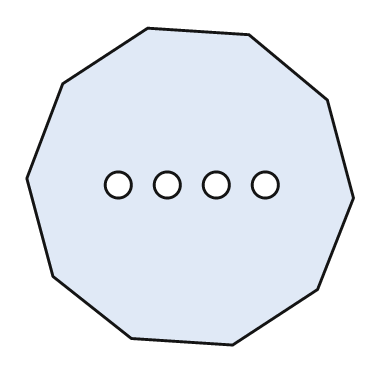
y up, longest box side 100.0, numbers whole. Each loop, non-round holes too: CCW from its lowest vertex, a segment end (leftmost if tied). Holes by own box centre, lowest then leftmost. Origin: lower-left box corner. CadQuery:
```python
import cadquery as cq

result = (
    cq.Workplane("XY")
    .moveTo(63.0, 0.0)
    .lineTo(89.0, 17.0)
    .lineTo(100.0, 45.0)
    .lineTo(92.0, 75.0)
    .lineTo(68.0, 95.0)
    .lineTo(37.0, 97.0)
    .lineTo(11.0, 80.0)
    .lineTo(0.0, 51.0)
    .lineTo(8.0, 21.0)
    .lineTo(32.0, 2.0)
    .close()
    .moveTo(28.0, 49.0)
    .circle(4.0)
    .moveTo(43.0, 49.0)
    .circle(4.0)
    .moveTo(58.0, 49.0)
    .circle(4.0)
    .moveTo(73.0, 49.0)
    .circle(4.0)
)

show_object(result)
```